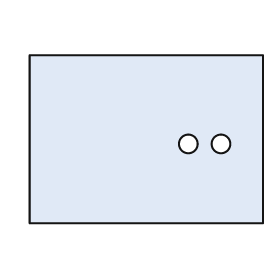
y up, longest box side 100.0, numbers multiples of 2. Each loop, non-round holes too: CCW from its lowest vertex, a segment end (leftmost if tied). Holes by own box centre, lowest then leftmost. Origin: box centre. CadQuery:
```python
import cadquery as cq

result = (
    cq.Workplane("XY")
    .moveTo(-50.0, -36.0)
    .lineTo(50.0, -36.0)
    .lineTo(50.0, 36.0)
    .lineTo(-50.0, 36.0)
    .close()
    .moveTo(18.0, -2.0)
    .circle(4.0)
    .moveTo(32.0, -2.0)
    .circle(4.0)
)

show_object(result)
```